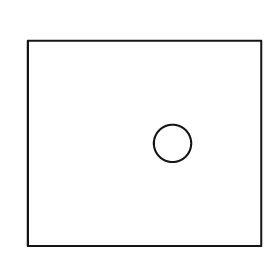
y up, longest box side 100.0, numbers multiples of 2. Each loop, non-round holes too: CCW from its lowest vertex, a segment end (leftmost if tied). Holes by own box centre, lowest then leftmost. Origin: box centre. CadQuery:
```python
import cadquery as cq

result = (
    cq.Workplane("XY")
    .moveTo(-50.0, -44.0)
    .lineTo(50.0, -44.0)
    .lineTo(50.0, 44.0)
    .lineTo(-50.0, 44.0)
    .close()
    .moveTo(12.0, 0.0)
    .circle(8.0)
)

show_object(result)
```